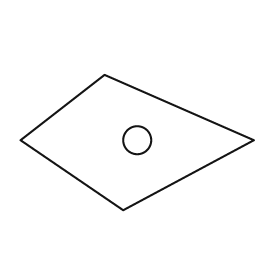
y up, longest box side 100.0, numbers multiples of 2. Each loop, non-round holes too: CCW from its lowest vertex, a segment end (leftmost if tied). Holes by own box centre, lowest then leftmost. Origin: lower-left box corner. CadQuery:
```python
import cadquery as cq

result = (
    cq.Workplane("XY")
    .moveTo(44.0, 0.0)
    .lineTo(100.0, 30.0)
    .lineTo(36.0, 58.0)
    .lineTo(0.0, 30.0)
    .close()
    .moveTo(50.0, 30.0)
    .circle(6.0)
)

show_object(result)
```